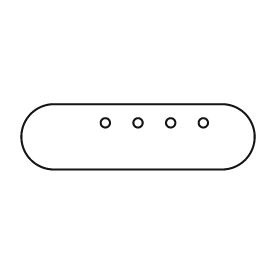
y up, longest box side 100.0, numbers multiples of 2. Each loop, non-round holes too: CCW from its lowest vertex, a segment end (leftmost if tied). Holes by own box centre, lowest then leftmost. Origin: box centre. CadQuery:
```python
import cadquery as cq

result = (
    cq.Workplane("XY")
    .moveTo(-36.0, -14.0)
    .lineTo(36.0, -14.0)
    .threePointArc((50.0, 0.0), (36.0, 14.0))
    .lineTo(-36.0, 14.0)
    .threePointArc((-50.0, 0.0), (-36.0, -14.0))
    .close()
    .moveTo(-14.0, 6.0)
    .circle(2.0)
    .moveTo(0.0, 6.0)
    .circle(2.0)
    .moveTo(14.0, 6.0)
    .circle(2.0)
    .moveTo(28.0, 6.0)
    .circle(2.0)
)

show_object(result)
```